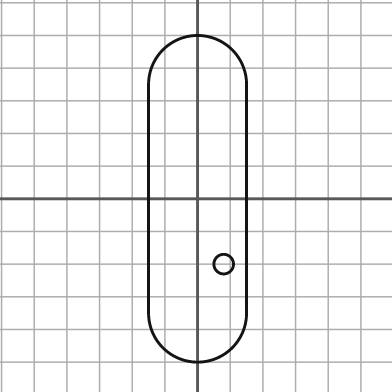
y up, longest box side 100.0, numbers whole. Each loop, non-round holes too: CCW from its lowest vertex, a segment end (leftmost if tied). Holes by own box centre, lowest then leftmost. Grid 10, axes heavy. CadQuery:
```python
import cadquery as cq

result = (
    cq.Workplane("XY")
    .moveTo(-15.0, -35.0)
    .threePointArc((0.0, -50.0), (15.0, -35.0))
    .lineTo(15.0, 35.0)
    .threePointArc((0.0, 50.0), (-15.0, 35.0))
    .close()
    .moveTo(8.0, -20.0)
    .circle(3.0)
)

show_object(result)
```